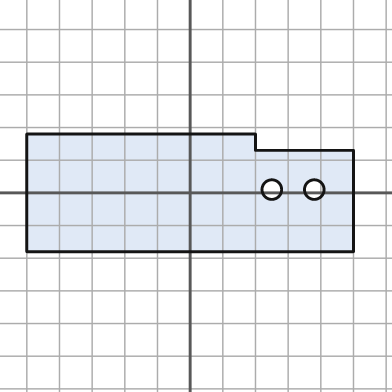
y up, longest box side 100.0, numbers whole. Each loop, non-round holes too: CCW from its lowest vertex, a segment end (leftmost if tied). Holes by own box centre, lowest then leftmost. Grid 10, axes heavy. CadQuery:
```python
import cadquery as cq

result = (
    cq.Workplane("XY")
    .moveTo(-50.0, -18.0)
    .lineTo(50.0, -18.0)
    .lineTo(50.0, 13.0)
    .lineTo(20.0, 13.0)
    .lineTo(20.0, 18.0)
    .lineTo(-50.0, 18.0)
    .close()
    .moveTo(25.0, 1.0)
    .circle(3.0)
    .moveTo(38.0, 1.0)
    .circle(3.0)
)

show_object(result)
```